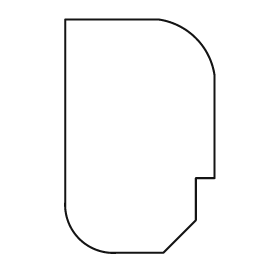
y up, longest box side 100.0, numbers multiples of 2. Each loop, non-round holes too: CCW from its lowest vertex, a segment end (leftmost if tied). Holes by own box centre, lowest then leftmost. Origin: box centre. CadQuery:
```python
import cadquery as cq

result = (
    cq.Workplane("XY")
    .moveTo(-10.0, -50.0)
    .lineTo(10.0, -50.0)
    .lineTo(24.0, -36.0)
    .lineTo(24.0, -18.0)
    .lineTo(32.0, -18.0)
    .lineTo(32.0, 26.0)
    .threePointArc((24.0, 42.0), (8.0, 50.0))
    .lineTo(-32.0, 50.0)
    .lineTo(-32.0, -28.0)
    .threePointArc((-26.0, -44.0), (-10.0, -50.0))
    .close()
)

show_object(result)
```